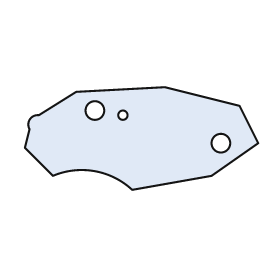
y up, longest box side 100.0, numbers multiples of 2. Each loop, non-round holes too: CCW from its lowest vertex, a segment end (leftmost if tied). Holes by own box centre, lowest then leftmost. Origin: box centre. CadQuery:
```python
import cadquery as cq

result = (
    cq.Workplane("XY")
    .moveTo(-4.0, -22.0)
    .lineTo(30.0, -16.0)
    .lineTo(50.0, -2.0)
    .lineTo(42.0, 14.0)
    .lineTo(10.0, 22.0)
    .lineTo(-28.0, 20.0)
    .lineTo(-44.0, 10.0)
    .threePointArc((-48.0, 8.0), (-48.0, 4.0))
    .lineTo(-50.0, -4.0)
    .lineTo(-38.0, -16.0)
    .threePointArc((-20.0, -14.0), (-4.0, -22.0))
    .close()
    .moveTo(34.0, -2.0)
    .circle(4.0)
    .moveTo(-8.0, 10.0)
    .circle(2.0)
    .moveTo(-20.0, 12.0)
    .circle(4.0)
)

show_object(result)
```